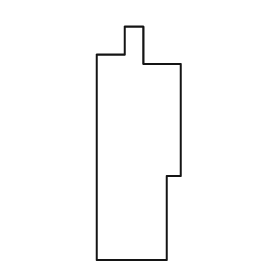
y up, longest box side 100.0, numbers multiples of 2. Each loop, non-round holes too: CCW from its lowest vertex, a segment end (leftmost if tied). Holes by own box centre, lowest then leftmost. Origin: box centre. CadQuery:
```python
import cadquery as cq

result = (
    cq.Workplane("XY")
    .moveTo(-18.0, -50.0)
    .lineTo(12.0, -50.0)
    .lineTo(12.0, -14.0)
    .lineTo(18.0, -14.0)
    .lineTo(18.0, 34.0)
    .lineTo(2.0, 34.0)
    .lineTo(2.0, 50.0)
    .lineTo(-6.0, 50.0)
    .lineTo(-6.0, 38.0)
    .lineTo(-18.0, 38.0)
    .close()
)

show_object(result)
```